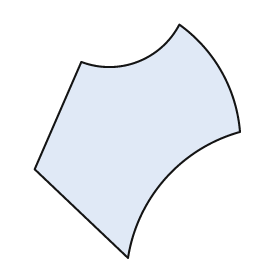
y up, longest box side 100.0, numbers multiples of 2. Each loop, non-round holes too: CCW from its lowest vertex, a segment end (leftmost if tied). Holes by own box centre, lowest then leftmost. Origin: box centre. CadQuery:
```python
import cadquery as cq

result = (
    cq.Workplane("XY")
    .moveTo(-4.0, -50.0)
    .threePointArc((12.0, -16.0), (44.0, 4.0))
    .threePointArc((36.0, 30.0), (18.0, 50.0))
    .threePointArc((0.0, 34.0), (-24.0, 34.0))
    .lineTo(-44.0, -12.0)
    .close()
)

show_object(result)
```